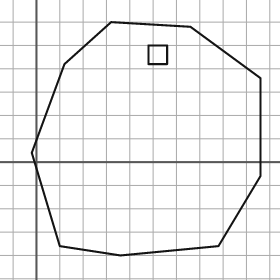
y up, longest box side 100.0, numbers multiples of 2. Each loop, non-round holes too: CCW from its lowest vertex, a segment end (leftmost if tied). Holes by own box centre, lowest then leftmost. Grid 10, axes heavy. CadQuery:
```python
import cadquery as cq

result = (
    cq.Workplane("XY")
    .moveTo(36.0, -40.0)
    .lineTo(78.0, -36.0)
    .lineTo(96.0, -6.0)
    .lineTo(96.0, 36.0)
    .lineTo(66.0, 58.0)
    .lineTo(32.0, 60.0)
    .lineTo(12.0, 42.0)
    .lineTo(-2.0, 4.0)
    .lineTo(10.0, -36.0)
    .close()
    .moveTo(48.0, 42.0)
    .lineTo(56.0, 42.0)
    .lineTo(56.0, 50.0)
    .lineTo(48.0, 50.0)
    .close()
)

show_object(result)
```